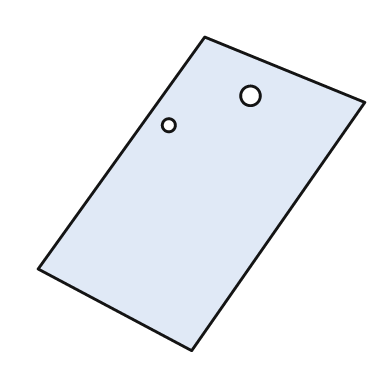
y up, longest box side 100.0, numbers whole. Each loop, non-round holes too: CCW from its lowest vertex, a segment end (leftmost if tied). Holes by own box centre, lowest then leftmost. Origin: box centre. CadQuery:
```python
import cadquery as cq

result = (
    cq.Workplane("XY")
    .moveTo(-3.0, -48.0)
    .lineTo(50.0, 28.0)
    .lineTo(1.0, 48.0)
    .lineTo(-50.0, -23.0)
    .close()
    .moveTo(-10.0, 21.0)
    .circle(2.0)
    .moveTo(15.0, 30.0)
    .circle(3.0)
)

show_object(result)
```